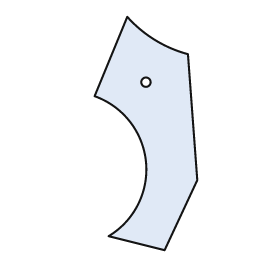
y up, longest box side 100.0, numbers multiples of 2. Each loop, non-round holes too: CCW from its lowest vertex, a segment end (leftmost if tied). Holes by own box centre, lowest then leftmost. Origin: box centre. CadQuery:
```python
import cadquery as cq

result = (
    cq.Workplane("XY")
    .moveTo(8.0, -50.0)
    .lineTo(22.0, -20.0)
    .lineTo(18.0, 34.0)
    .threePointArc((4.0, 40.0), (-8.0, 50.0))
    .lineTo(-22.0, 16.0)
    .threePointArc((0.0, -12.0), (-16.0, -44.0))
    .close()
    .moveTo(0.0, 22.0)
    .circle(2.0)
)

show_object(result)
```